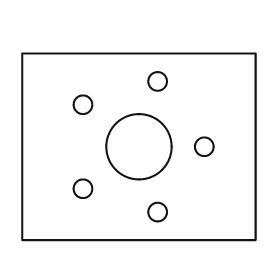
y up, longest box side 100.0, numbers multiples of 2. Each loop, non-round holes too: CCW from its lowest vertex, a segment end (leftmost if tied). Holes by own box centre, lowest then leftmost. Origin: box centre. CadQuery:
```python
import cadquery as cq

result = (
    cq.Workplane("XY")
    .moveTo(-50.0, -40.0)
    .lineTo(50.0, -40.0)
    .lineTo(50.0, 40.0)
    .lineTo(-50.0, 40.0)
    .close()
    .moveTo(8.0, -28.0)
    .circle(4.0)
    .moveTo(-24.0, -18.0)
    .circle(4.0)
    .moveTo(0.0, 0.0)
    .circle(14.0)
    .moveTo(28.0, 0.0)
    .circle(4.0)
    .moveTo(-24.0, 18.0)
    .circle(4.0)
    .moveTo(8.0, 28.0)
    .circle(4.0)
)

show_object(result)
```